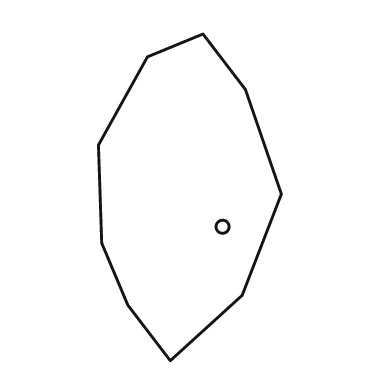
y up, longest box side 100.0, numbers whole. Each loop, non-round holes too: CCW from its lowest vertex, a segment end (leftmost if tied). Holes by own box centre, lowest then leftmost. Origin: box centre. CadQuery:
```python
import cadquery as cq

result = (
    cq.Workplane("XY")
    .moveTo(-6.0, -50.0)
    .lineTo(16.0, -30.0)
    .lineTo(28.0, 1.0)
    .lineTo(17.0, 33.0)
    .lineTo(4.0, 50.0)
    .lineTo(-13.0, 43.0)
    .lineTo(-28.0, 16.0)
    .lineTo(-27.0, -14.0)
    .lineTo(-19.0, -33.0)
    .close()
    .moveTo(10.0, -9.0)
    .circle(2.0)
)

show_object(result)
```